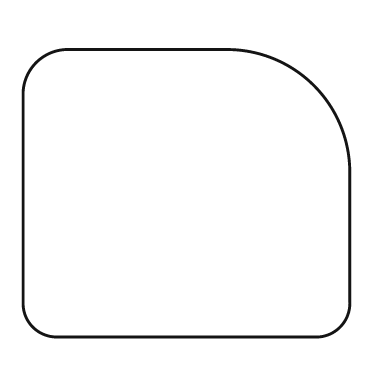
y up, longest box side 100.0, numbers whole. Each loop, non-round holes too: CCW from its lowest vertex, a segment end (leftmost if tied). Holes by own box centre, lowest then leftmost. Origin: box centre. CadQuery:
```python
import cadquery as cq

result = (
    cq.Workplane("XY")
    .moveTo(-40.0, -44.0)
    .lineTo(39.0, -44.0)
    .threePointArc((47.0, -41.0), (50.0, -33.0))
    .lineTo(50.0, 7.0)
    .threePointArc((39.0, 33.0), (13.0, 44.0))
    .lineTo(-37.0, 44.0)
    .threePointArc((-46.0, 40.0), (-50.0, 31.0))
    .lineTo(-50.0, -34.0)
    .threePointArc((-47.0, -41.0), (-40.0, -44.0))
    .close()
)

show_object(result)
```